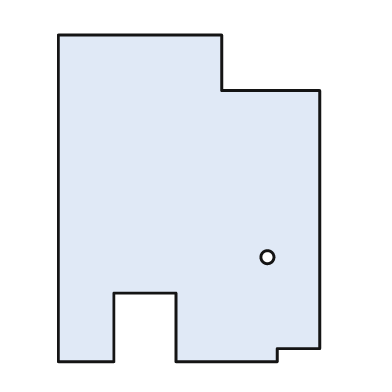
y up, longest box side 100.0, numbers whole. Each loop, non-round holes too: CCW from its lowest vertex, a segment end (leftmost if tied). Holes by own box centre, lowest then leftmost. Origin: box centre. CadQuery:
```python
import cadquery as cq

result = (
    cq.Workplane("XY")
    .moveTo(-40.0, -50.0)
    .lineTo(-23.0, -50.0)
    .lineTo(-23.0, -29.0)
    .lineTo(-4.0, -29.0)
    .lineTo(-4.0, -50.0)
    .lineTo(27.0, -50.0)
    .lineTo(27.0, -46.0)
    .lineTo(40.0, -46.0)
    .lineTo(40.0, 33.0)
    .lineTo(10.0, 33.0)
    .lineTo(10.0, 50.0)
    .lineTo(-40.0, 50.0)
    .close()
    .moveTo(24.0, -18.0)
    .circle(2.0)
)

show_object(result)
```